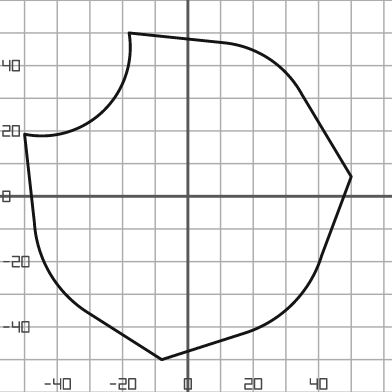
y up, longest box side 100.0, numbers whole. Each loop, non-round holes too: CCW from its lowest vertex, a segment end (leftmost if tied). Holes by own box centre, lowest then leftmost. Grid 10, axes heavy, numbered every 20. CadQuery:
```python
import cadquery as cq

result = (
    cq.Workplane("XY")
    .moveTo(-8.0, -50.0)
    .lineTo(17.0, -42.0)
    .threePointArc((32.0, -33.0), (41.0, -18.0))
    .lineTo(50.0, 6.0)
    .lineTo(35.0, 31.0)
    .threePointArc((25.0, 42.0), (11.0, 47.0))
    .lineTo(-18.0, 50.0)
    .threePointArc((-26.0, 26.0), (-50.0, 19.0))
    .lineTo(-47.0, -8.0)
    .threePointArc((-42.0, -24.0), (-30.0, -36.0))
    .close()
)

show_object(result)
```